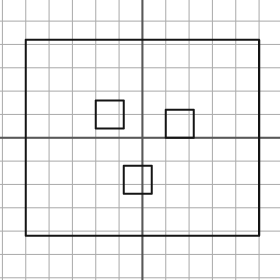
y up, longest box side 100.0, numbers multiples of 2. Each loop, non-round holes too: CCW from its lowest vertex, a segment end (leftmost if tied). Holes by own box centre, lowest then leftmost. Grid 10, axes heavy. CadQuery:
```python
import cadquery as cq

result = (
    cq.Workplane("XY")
    .moveTo(-50.0, -42.0)
    .lineTo(50.0, -42.0)
    .lineTo(50.0, 42.0)
    .lineTo(-50.0, 42.0)
    .close()
    .moveTo(-8.0, -24.0)
    .lineTo(4.0, -24.0)
    .lineTo(4.0, -12.0)
    .lineTo(-8.0, -12.0)
    .close()
    .moveTo(10.0, 0.0)
    .lineTo(22.0, 0.0)
    .lineTo(22.0, 12.0)
    .lineTo(10.0, 12.0)
    .close()
    .moveTo(-20.0, 4.0)
    .lineTo(-8.0, 4.0)
    .lineTo(-8.0, 16.0)
    .lineTo(-20.0, 16.0)
    .close()
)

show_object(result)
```